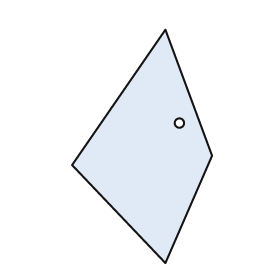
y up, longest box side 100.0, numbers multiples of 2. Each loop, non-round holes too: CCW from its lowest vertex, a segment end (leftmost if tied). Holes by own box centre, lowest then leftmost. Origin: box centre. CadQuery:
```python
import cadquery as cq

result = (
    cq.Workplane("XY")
    .moveTo(10.0, -50.0)
    .lineTo(30.0, -4.0)
    .lineTo(10.0, 50.0)
    .lineTo(-30.0, -8.0)
    .close()
    .moveTo(16.0, 10.0)
    .circle(2.0)
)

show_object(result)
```